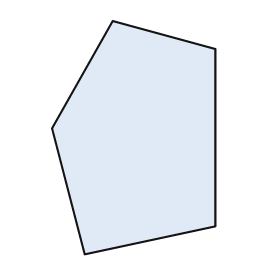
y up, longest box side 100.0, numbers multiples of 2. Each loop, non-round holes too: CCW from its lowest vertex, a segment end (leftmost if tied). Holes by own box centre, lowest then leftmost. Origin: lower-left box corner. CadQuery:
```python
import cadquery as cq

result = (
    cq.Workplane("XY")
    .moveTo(14.0, 0.0)
    .lineTo(70.0, 12.0)
    .lineTo(70.0, 88.0)
    .lineTo(26.0, 100.0)
    .lineTo(0.0, 54.0)
    .close()
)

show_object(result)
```